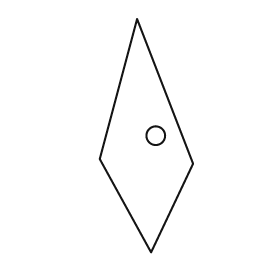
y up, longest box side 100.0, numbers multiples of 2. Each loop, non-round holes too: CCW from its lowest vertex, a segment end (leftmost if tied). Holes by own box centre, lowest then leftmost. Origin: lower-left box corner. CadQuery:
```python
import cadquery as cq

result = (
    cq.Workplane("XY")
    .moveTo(22.0, 0.0)
    .lineTo(40.0, 38.0)
    .lineTo(16.0, 100.0)
    .lineTo(0.0, 40.0)
    .close()
    .moveTo(24.0, 50.0)
    .circle(4.0)
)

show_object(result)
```